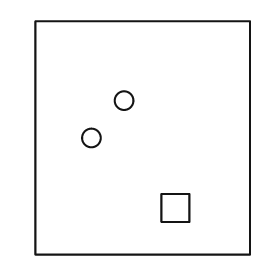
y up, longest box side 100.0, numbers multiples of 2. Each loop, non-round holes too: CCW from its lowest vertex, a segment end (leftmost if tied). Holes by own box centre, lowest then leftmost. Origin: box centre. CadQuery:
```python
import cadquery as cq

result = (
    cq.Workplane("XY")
    .moveTo(-46.0, -50.0)
    .lineTo(46.0, -50.0)
    .lineTo(46.0, 50.0)
    .lineTo(-46.0, 50.0)
    .close()
    .moveTo(8.0, -36.0)
    .lineTo(20.0, -36.0)
    .lineTo(20.0, -24.0)
    .lineTo(8.0, -24.0)
    .close()
    .moveTo(-22.0, 0.0)
    .circle(4.0)
    .moveTo(-8.0, 16.0)
    .circle(4.0)
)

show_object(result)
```